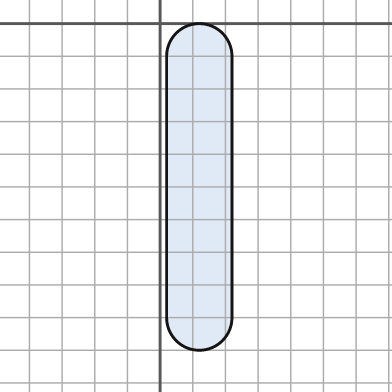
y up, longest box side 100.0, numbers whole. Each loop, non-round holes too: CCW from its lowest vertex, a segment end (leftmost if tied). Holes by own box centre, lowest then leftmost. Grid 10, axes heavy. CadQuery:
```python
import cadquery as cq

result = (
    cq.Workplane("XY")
    .moveTo(2.0, -90.0)
    .threePointArc((12.0, -100.0), (22.0, -90.0))
    .lineTo(22.0, -10.0)
    .threePointArc((12.0, 0.0), (2.0, -10.0))
    .close()
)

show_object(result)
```